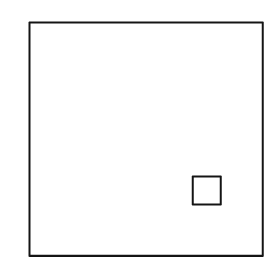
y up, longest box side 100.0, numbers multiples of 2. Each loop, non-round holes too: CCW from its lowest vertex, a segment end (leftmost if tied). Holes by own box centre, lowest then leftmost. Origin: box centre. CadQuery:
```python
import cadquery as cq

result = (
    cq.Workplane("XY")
    .moveTo(-50.0, -50.0)
    .lineTo(50.0, -50.0)
    .lineTo(50.0, 50.0)
    .lineTo(-50.0, 50.0)
    .close()
    .moveTo(20.0, -28.0)
    .lineTo(32.0, -28.0)
    .lineTo(32.0, -16.0)
    .lineTo(20.0, -16.0)
    .close()
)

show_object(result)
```